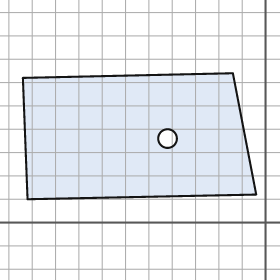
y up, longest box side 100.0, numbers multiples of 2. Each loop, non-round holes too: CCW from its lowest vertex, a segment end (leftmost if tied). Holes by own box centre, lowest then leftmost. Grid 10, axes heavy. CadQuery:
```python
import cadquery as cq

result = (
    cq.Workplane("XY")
    .moveTo(-102.0, 10.0)
    .lineTo(-4.0, 12.0)
    .lineTo(-14.0, 64.0)
    .lineTo(-104.0, 62.0)
    .close()
    .moveTo(-42.0, 36.0)
    .circle(4.0)
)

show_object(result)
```